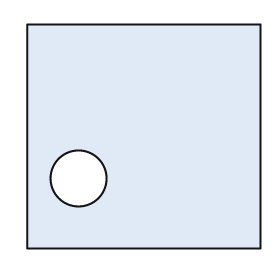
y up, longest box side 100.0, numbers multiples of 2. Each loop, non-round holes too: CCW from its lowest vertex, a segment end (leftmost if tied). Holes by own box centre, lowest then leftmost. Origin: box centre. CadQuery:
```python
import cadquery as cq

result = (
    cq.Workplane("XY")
    .moveTo(-50.0, -48.0)
    .lineTo(50.0, -48.0)
    .lineTo(50.0, 48.0)
    .lineTo(-50.0, 48.0)
    .close()
    .moveTo(-28.0, -18.0)
    .circle(12.0)
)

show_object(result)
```